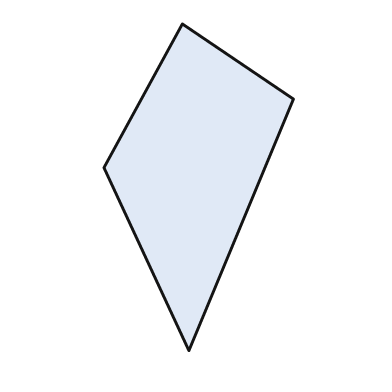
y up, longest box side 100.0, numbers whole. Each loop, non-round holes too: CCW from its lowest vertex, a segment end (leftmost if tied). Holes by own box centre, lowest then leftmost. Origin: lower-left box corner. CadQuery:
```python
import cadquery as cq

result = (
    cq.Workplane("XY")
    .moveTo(26.0, 0.0)
    .lineTo(58.0, 77.0)
    .lineTo(24.0, 100.0)
    .lineTo(0.0, 56.0)
    .close()
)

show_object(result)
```